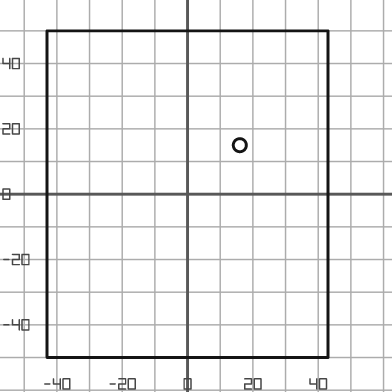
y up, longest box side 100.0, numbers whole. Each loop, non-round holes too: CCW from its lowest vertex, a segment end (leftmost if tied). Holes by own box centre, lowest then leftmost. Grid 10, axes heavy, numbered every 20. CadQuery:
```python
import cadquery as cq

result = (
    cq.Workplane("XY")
    .moveTo(-43.0, -50.0)
    .lineTo(43.0, -50.0)
    .lineTo(43.0, 50.0)
    .lineTo(-43.0, 50.0)
    .close()
    .moveTo(16.0, 15.0)
    .circle(2.0)
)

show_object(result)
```